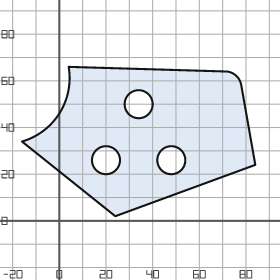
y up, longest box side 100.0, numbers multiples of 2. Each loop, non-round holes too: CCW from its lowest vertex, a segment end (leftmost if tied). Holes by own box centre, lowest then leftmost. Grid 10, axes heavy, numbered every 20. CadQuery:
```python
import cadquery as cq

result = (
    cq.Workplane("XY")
    .moveTo(24.0, 2.0)
    .lineTo(84.0, 24.0)
    .lineTo(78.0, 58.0)
    .threePointArc((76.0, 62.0), (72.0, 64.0))
    .lineTo(4.0, 66.0)
    .threePointArc((0.0, 46.0), (-16.0, 34.0))
    .close()
    .moveTo(20.0, 26.0)
    .circle(6.0)
    .moveTo(48.0, 26.0)
    .circle(6.0)
    .moveTo(34.0, 50.0)
    .circle(6.0)
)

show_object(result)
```